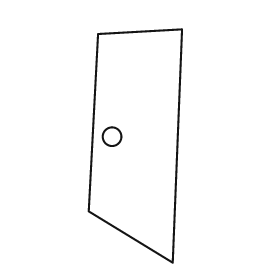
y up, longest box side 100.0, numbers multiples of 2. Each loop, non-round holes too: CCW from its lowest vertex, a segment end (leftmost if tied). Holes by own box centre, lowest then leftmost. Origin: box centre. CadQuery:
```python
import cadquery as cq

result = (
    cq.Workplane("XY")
    .moveTo(16.0, -50.0)
    .lineTo(20.0, 50.0)
    .lineTo(-16.0, 48.0)
    .lineTo(-20.0, -28.0)
    .close()
    .moveTo(-10.0, 4.0)
    .circle(4.0)
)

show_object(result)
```